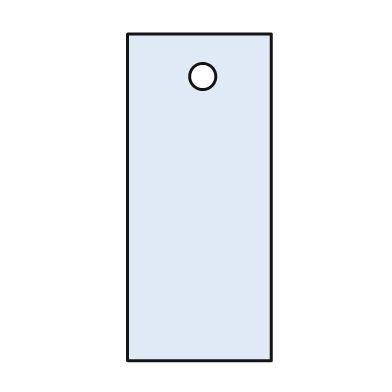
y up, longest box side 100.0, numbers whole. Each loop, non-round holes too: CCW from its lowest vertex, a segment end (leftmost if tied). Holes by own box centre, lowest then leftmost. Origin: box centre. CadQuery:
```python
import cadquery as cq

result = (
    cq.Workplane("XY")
    .moveTo(-22.0, -50.0)
    .lineTo(22.0, -50.0)
    .lineTo(22.0, 50.0)
    .lineTo(-22.0, 50.0)
    .close()
    .moveTo(1.0, 37.0)
    .circle(4.0)
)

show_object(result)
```